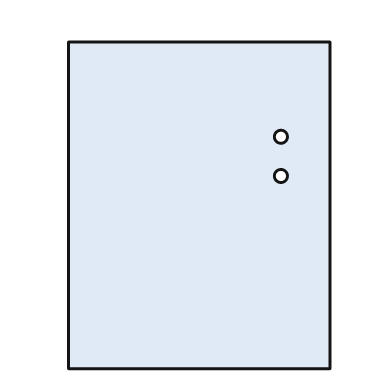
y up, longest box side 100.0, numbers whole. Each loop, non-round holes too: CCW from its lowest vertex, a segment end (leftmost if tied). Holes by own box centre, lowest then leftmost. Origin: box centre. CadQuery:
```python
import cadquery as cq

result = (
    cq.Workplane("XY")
    .moveTo(-40.0, -50.0)
    .lineTo(40.0, -50.0)
    .lineTo(40.0, 50.0)
    .lineTo(-40.0, 50.0)
    .close()
    .moveTo(25.0, 9.0)
    .circle(2.0)
    .moveTo(25.0, 21.0)
    .circle(2.0)
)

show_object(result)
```